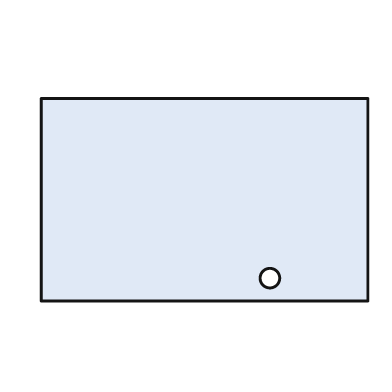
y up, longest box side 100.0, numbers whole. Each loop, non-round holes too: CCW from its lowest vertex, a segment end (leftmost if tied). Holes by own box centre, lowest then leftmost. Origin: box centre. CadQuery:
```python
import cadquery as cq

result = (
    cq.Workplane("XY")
    .moveTo(-50.0, -31.0)
    .lineTo(50.0, -31.0)
    .lineTo(50.0, 31.0)
    .lineTo(-50.0, 31.0)
    .close()
    .moveTo(20.0, -24.0)
    .circle(3.0)
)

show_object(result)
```